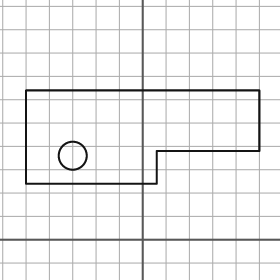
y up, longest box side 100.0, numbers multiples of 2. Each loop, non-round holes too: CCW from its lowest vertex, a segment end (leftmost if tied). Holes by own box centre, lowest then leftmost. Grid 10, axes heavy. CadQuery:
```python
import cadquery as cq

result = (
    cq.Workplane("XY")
    .moveTo(-50.0, 24.0)
    .lineTo(6.0, 24.0)
    .lineTo(6.0, 38.0)
    .lineTo(50.0, 38.0)
    .lineTo(50.0, 64.0)
    .lineTo(-50.0, 64.0)
    .close()
    .moveTo(-30.0, 36.0)
    .circle(6.0)
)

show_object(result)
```